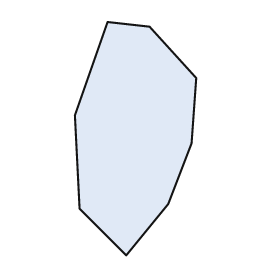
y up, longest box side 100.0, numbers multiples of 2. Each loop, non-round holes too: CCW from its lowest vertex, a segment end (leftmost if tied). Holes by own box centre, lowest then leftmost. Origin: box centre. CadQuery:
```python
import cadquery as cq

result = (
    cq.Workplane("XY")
    .moveTo(-4.0, -50.0)
    .lineTo(14.0, -28.0)
    .lineTo(24.0, -2.0)
    .lineTo(26.0, 26.0)
    .lineTo(6.0, 48.0)
    .lineTo(-12.0, 50.0)
    .lineTo(-26.0, 10.0)
    .lineTo(-24.0, -30.0)
    .close()
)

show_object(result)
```